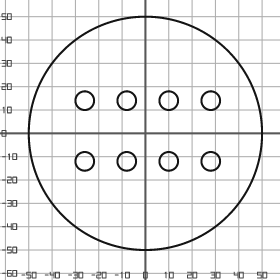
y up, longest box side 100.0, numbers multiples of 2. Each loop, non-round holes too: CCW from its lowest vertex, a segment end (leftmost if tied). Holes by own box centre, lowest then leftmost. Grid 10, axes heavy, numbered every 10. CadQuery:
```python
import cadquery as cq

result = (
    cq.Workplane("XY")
    .moveTo(0.0, 0.0)
    .circle(50.0)
    .moveTo(-26.0, -12.0)
    .circle(4.0)
    .moveTo(-8.0, -12.0)
    .circle(4.0)
    .moveTo(10.0, -12.0)
    .circle(4.0)
    .moveTo(28.0, -12.0)
    .circle(4.0)
    .moveTo(-26.0, 14.0)
    .circle(4.0)
    .moveTo(-8.0, 14.0)
    .circle(4.0)
    .moveTo(10.0, 14.0)
    .circle(4.0)
    .moveTo(28.0, 14.0)
    .circle(4.0)
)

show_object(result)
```